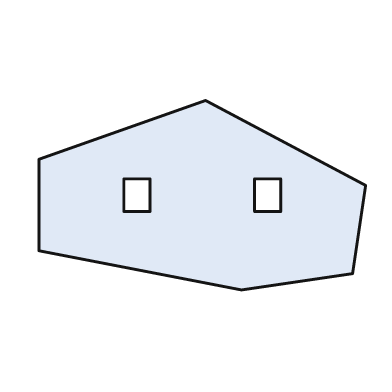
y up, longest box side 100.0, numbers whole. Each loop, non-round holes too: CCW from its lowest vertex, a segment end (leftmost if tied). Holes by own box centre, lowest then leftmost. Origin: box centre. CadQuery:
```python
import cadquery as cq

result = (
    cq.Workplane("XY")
    .moveTo(12.0, -29.0)
    .lineTo(46.0, -24.0)
    .lineTo(50.0, 3.0)
    .lineTo(1.0, 29.0)
    .lineTo(-50.0, 11.0)
    .lineTo(-50.0, -17.0)
    .close()
    .moveTo(-24.0, -5.0)
    .lineTo(-16.0, -5.0)
    .lineTo(-16.0, 5.0)
    .lineTo(-24.0, 5.0)
    .close()
    .moveTo(16.0, -5.0)
    .lineTo(24.0, -5.0)
    .lineTo(24.0, 5.0)
    .lineTo(16.0, 5.0)
    .close()
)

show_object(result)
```